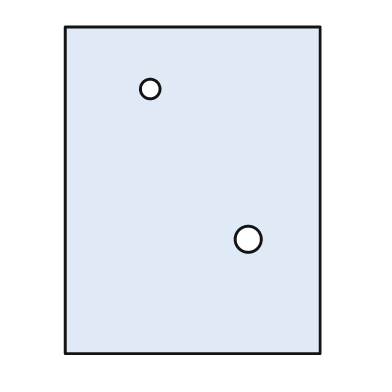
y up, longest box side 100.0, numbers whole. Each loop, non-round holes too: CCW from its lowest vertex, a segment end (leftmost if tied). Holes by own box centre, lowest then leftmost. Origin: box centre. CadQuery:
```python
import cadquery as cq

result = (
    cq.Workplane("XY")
    .moveTo(-39.0, -50.0)
    .lineTo(39.0, -50.0)
    .lineTo(39.0, 50.0)
    .lineTo(-39.0, 50.0)
    .close()
    .moveTo(17.0, -15.0)
    .circle(4.0)
    .moveTo(-13.0, 31.0)
    .circle(3.0)
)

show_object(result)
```